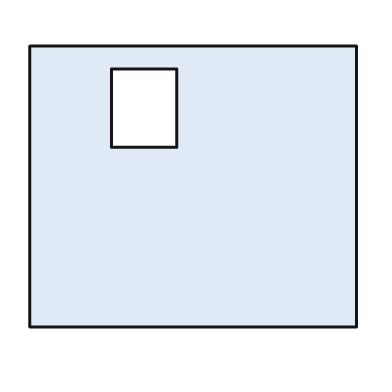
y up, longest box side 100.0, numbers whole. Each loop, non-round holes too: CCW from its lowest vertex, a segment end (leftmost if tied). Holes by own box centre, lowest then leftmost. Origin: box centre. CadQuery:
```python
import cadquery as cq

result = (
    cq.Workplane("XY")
    .moveTo(-50.0, -43.0)
    .lineTo(50.0, -43.0)
    .lineTo(50.0, 43.0)
    .lineTo(-50.0, 43.0)
    .close()
    .moveTo(-25.0, 12.0)
    .lineTo(-5.0, 12.0)
    .lineTo(-5.0, 36.0)
    .lineTo(-25.0, 36.0)
    .close()
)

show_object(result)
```